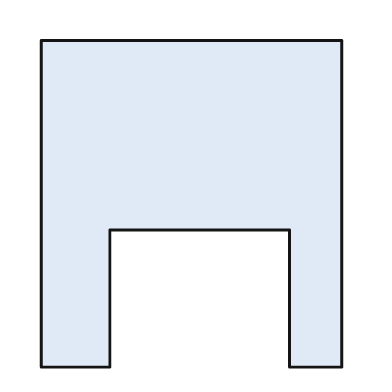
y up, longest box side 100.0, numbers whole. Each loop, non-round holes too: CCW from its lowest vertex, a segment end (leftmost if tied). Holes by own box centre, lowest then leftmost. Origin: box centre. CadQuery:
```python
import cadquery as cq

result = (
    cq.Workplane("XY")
    .moveTo(-46.0, -50.0)
    .lineTo(-25.0, -50.0)
    .lineTo(-25.0, -8.0)
    .lineTo(30.0, -8.0)
    .lineTo(30.0, -50.0)
    .lineTo(46.0, -50.0)
    .lineTo(46.0, 50.0)
    .lineTo(-46.0, 50.0)
    .close()
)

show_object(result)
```